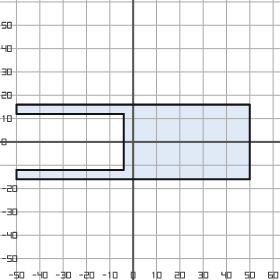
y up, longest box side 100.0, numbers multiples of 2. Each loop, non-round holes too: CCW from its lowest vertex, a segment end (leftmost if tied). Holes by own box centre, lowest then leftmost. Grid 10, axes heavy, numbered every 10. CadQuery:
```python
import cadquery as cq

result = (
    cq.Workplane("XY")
    .moveTo(-50.0, -16.0)
    .lineTo(50.0, -16.0)
    .lineTo(50.0, 16.0)
    .lineTo(-50.0, 16.0)
    .lineTo(-50.0, 12.0)
    .lineTo(-4.0, 12.0)
    .lineTo(-4.0, -12.0)
    .lineTo(-50.0, -12.0)
    .close()
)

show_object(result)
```